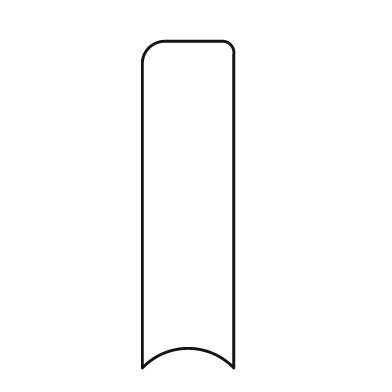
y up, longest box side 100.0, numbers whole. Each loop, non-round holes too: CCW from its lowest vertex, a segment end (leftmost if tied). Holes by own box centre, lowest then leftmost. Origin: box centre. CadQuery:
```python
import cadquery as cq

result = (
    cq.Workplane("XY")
    .moveTo(-14.0, -50.0)
    .threePointArc((0.0, -44.0), (14.0, -50.0))
    .lineTo(14.0, 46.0)
    .threePointArc((13.0, 49.0), (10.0, 50.0))
    .lineTo(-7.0, 50.0)
    .threePointArc((-12.0, 48.0), (-14.0, 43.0))
    .close()
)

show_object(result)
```